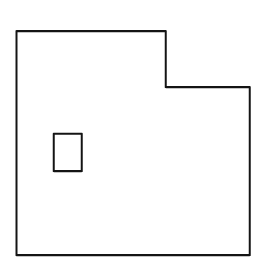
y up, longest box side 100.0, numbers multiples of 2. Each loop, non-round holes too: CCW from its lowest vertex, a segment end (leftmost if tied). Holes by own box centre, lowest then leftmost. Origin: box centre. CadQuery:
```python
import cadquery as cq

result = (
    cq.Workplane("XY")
    .moveTo(-50.0, -48.0)
    .lineTo(50.0, -48.0)
    .lineTo(50.0, 24.0)
    .lineTo(14.0, 24.0)
    .lineTo(14.0, 48.0)
    .lineTo(-50.0, 48.0)
    .close()
    .moveTo(-34.0, -12.0)
    .lineTo(-22.0, -12.0)
    .lineTo(-22.0, 4.0)
    .lineTo(-34.0, 4.0)
    .close()
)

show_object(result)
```